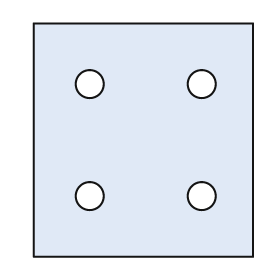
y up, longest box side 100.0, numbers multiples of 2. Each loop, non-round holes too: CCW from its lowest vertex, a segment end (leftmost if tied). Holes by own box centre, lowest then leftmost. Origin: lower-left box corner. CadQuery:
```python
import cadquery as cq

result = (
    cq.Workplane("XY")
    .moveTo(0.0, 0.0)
    .lineTo(94.0, 0.0)
    .lineTo(94.0, 100.0)
    .lineTo(0.0, 100.0)
    .close()
    .moveTo(24.0, 26.0)
    .circle(6.0)
    .moveTo(72.0, 26.0)
    .circle(6.0)
    .moveTo(24.0, 74.0)
    .circle(6.0)
    .moveTo(72.0, 74.0)
    .circle(6.0)
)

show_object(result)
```